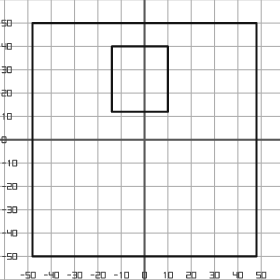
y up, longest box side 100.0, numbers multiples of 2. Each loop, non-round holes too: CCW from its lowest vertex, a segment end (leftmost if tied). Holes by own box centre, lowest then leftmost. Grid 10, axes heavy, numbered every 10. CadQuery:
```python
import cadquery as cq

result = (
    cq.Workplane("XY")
    .moveTo(-48.0, -50.0)
    .lineTo(48.0, -50.0)
    .lineTo(48.0, 50.0)
    .lineTo(-48.0, 50.0)
    .close()
    .moveTo(-14.0, 12.0)
    .lineTo(10.0, 12.0)
    .lineTo(10.0, 40.0)
    .lineTo(-14.0, 40.0)
    .close()
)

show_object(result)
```